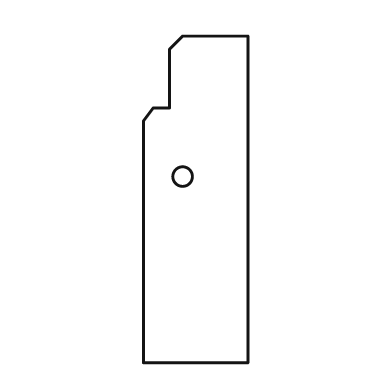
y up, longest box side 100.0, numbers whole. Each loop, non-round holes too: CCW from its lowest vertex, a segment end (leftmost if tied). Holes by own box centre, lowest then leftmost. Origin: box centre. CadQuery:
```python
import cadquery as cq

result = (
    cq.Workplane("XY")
    .moveTo(-16.0, -50.0)
    .lineTo(16.0, -50.0)
    .lineTo(16.0, 50.0)
    .lineTo(-4.0, 50.0)
    .lineTo(-8.0, 46.0)
    .lineTo(-8.0, 28.0)
    .lineTo(-13.0, 28.0)
    .lineTo(-16.0, 24.0)
    .close()
    .moveTo(-4.0, 7.0)
    .circle(3.0)
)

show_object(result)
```